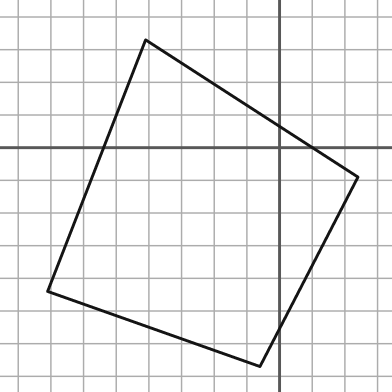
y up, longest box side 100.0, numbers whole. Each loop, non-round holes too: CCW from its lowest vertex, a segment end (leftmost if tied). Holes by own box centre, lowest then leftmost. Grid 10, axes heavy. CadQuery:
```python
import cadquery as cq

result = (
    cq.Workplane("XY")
    .moveTo(-6.0, -67.0)
    .lineTo(24.0, -9.0)
    .lineTo(-41.0, 33.0)
    .lineTo(-71.0, -44.0)
    .close()
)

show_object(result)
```